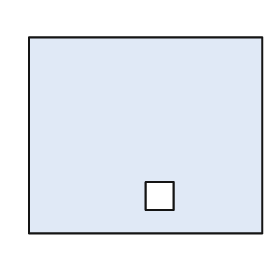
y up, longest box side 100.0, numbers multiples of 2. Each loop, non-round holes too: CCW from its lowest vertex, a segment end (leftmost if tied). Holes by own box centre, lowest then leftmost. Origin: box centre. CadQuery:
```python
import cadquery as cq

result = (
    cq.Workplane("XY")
    .moveTo(-50.0, -42.0)
    .lineTo(50.0, -42.0)
    .lineTo(50.0, 42.0)
    .lineTo(-50.0, 42.0)
    .close()
    .moveTo(0.0, -32.0)
    .lineTo(12.0, -32.0)
    .lineTo(12.0, -20.0)
    .lineTo(0.0, -20.0)
    .close()
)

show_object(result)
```